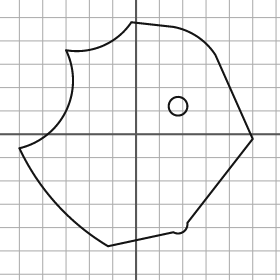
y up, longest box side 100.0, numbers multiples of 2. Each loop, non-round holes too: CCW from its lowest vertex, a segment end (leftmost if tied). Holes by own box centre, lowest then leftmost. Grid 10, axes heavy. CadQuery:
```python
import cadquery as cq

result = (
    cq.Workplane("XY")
    .moveTo(-12.0, -48.0)
    .lineTo(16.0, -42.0)
    .threePointArc((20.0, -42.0), (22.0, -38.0))
    .lineTo(50.0, -2.0)
    .lineTo(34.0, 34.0)
    .threePointArc((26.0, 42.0), (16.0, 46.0))
    .lineTo(-2.0, 48.0)
    .threePointArc((-14.0, 38.0), (-30.0, 36.0))
    .threePointArc((-30.0, 10.0), (-50.0, -6.0))
    .threePointArc((-34.0, -30.0), (-12.0, -48.0))
    .close()
    .moveTo(18.0, 12.0)
    .circle(4.0)
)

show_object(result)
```